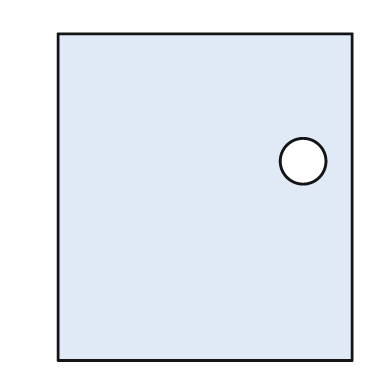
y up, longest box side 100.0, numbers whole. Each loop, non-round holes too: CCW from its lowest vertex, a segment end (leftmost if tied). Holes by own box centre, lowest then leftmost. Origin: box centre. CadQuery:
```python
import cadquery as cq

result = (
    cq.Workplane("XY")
    .moveTo(-45.0, -50.0)
    .lineTo(45.0, -50.0)
    .lineTo(45.0, 50.0)
    .lineTo(-45.0, 50.0)
    .close()
    .moveTo(30.0, 11.0)
    .circle(7.0)
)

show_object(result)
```